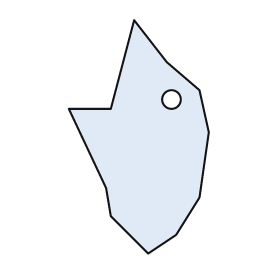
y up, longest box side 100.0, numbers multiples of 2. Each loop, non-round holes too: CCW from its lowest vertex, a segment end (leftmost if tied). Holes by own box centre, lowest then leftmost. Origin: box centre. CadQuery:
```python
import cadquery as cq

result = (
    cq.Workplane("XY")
    .moveTo(4.0, -50.0)
    .lineTo(16.0, -42.0)
    .lineTo(26.0, -26.0)
    .lineTo(30.0, 2.0)
    .lineTo(26.0, 20.0)
    .lineTo(12.0, 32.0)
    .lineTo(-2.0, 50.0)
    .lineTo(-12.0, 12.0)
    .lineTo(-30.0, 12.0)
    .lineTo(-14.0, -22.0)
    .lineTo(-12.0, -34.0)
    .close()
    .moveTo(14.0, 16.0)
    .circle(4.0)
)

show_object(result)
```